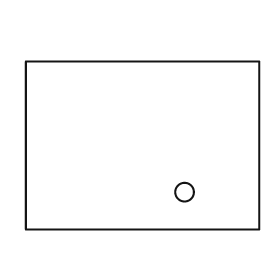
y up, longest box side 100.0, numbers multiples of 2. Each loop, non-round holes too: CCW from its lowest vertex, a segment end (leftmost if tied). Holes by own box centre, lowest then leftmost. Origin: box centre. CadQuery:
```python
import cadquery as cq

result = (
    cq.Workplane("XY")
    .moveTo(-50.0, -36.0)
    .lineTo(50.0, -36.0)
    .lineTo(50.0, 36.0)
    .lineTo(-50.0, 36.0)
    .close()
    .moveTo(18.0, -20.0)
    .circle(4.0)
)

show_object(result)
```